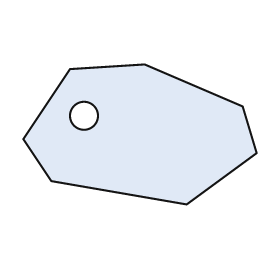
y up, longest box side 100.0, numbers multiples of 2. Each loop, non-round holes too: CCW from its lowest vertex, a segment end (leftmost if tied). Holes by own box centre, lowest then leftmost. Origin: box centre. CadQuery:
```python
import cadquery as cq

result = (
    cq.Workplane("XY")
    .moveTo(20.0, -30.0)
    .lineTo(50.0, -8.0)
    .lineTo(44.0, 12.0)
    .lineTo(2.0, 30.0)
    .lineTo(-30.0, 28.0)
    .lineTo(-50.0, -2.0)
    .lineTo(-38.0, -20.0)
    .close()
    .moveTo(-24.0, 8.0)
    .circle(6.0)
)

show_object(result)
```